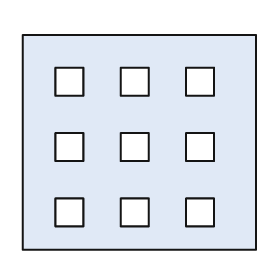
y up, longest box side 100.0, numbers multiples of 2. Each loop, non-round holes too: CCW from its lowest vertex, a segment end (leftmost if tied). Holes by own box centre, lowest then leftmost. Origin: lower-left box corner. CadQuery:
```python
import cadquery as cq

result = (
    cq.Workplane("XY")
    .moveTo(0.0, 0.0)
    .lineTo(100.0, 0.0)
    .lineTo(100.0, 92.0)
    .lineTo(0.0, 92.0)
    .close()
    .moveTo(14.0, 10.0)
    .lineTo(26.0, 10.0)
    .lineTo(26.0, 22.0)
    .lineTo(14.0, 22.0)
    .close()
    .moveTo(42.0, 10.0)
    .lineTo(54.0, 10.0)
    .lineTo(54.0, 22.0)
    .lineTo(42.0, 22.0)
    .close()
    .moveTo(70.0, 10.0)
    .lineTo(82.0, 10.0)
    .lineTo(82.0, 22.0)
    .lineTo(70.0, 22.0)
    .close()
    .moveTo(14.0, 38.0)
    .lineTo(26.0, 38.0)
    .lineTo(26.0, 50.0)
    .lineTo(14.0, 50.0)
    .close()
    .moveTo(42.0, 38.0)
    .lineTo(54.0, 38.0)
    .lineTo(54.0, 50.0)
    .lineTo(42.0, 50.0)
    .close()
    .moveTo(70.0, 38.0)
    .lineTo(82.0, 38.0)
    .lineTo(82.0, 50.0)
    .lineTo(70.0, 50.0)
    .close()
    .moveTo(14.0, 66.0)
    .lineTo(26.0, 66.0)
    .lineTo(26.0, 78.0)
    .lineTo(14.0, 78.0)
    .close()
    .moveTo(42.0, 66.0)
    .lineTo(54.0, 66.0)
    .lineTo(54.0, 78.0)
    .lineTo(42.0, 78.0)
    .close()
    .moveTo(70.0, 66.0)
    .lineTo(82.0, 66.0)
    .lineTo(82.0, 78.0)
    .lineTo(70.0, 78.0)
    .close()
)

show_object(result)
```